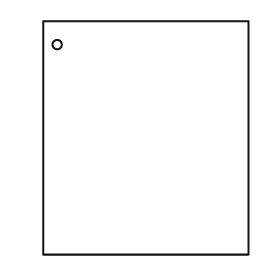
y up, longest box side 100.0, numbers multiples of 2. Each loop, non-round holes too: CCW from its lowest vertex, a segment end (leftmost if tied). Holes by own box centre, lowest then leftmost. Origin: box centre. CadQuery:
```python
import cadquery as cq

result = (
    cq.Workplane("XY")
    .moveTo(-44.0, -50.0)
    .lineTo(44.0, -50.0)
    .lineTo(44.0, 50.0)
    .lineTo(-44.0, 50.0)
    .close()
    .moveTo(-38.0, 40.0)
    .circle(2.0)
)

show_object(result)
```